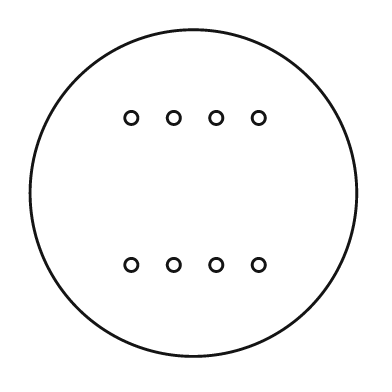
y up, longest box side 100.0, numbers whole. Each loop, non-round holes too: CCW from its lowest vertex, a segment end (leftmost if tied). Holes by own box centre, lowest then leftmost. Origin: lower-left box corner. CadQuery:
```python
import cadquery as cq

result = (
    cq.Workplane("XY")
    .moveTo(50.0, 50.0)
    .circle(50.0)
    .moveTo(31.0, 28.0)
    .circle(2.0)
    .moveTo(44.0, 28.0)
    .circle(2.0)
    .moveTo(57.0, 28.0)
    .circle(2.0)
    .moveTo(70.0, 28.0)
    .circle(2.0)
    .moveTo(31.0, 73.0)
    .circle(2.0)
    .moveTo(44.0, 73.0)
    .circle(2.0)
    .moveTo(57.0, 73.0)
    .circle(2.0)
    .moveTo(70.0, 73.0)
    .circle(2.0)
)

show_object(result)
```